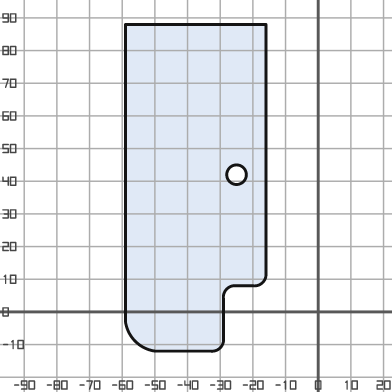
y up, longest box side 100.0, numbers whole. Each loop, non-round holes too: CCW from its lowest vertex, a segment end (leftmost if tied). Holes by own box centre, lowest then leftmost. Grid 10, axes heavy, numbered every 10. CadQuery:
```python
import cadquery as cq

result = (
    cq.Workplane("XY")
    .moveTo(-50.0, -12.0)
    .lineTo(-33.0, -12.0)
    .threePointArc((-30.0, -11.0), (-29.0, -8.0))
    .lineTo(-29.0, 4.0)
    .threePointArc((-28.0, 7.0), (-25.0, 8.0))
    .lineTo(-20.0, 8.0)
    .threePointArc((-17.0, 9.0), (-16.0, 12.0))
    .lineTo(-16.0, 88.0)
    .lineTo(-59.0, 88.0)
    .lineTo(-59.0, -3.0)
    .threePointArc((-56.0, -9.0), (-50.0, -12.0))
    .close()
    .moveTo(-25.0, 42.0)
    .circle(3.0)
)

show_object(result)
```